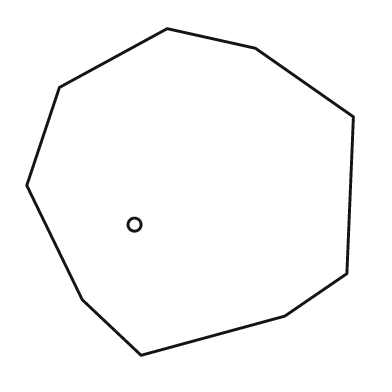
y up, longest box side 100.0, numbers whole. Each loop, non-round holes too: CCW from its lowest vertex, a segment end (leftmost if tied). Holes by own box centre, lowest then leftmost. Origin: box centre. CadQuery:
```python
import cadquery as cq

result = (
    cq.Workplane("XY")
    .moveTo(-15.0, -50.0)
    .lineTo(29.0, -38.0)
    .lineTo(48.0, -25.0)
    .lineTo(50.0, 23.0)
    .lineTo(20.0, 44.0)
    .lineTo(-7.0, 50.0)
    .lineTo(-40.0, 32.0)
    .lineTo(-50.0, 2.0)
    .lineTo(-33.0, -33.0)
    .close()
    .moveTo(-17.0, -10.0)
    .circle(2.0)
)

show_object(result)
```